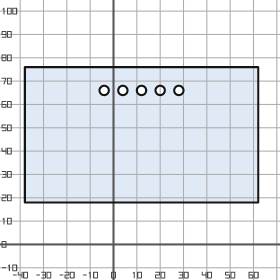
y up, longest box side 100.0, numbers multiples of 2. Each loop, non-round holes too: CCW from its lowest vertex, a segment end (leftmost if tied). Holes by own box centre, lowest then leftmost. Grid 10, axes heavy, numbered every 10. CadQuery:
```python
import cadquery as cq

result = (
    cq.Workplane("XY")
    .moveTo(-38.0, 18.0)
    .lineTo(62.0, 18.0)
    .lineTo(62.0, 76.0)
    .lineTo(-38.0, 76.0)
    .close()
    .moveTo(-4.0, 66.0)
    .circle(2.0)
    .moveTo(4.0, 66.0)
    .circle(2.0)
    .moveTo(12.0, 66.0)
    .circle(2.0)
    .moveTo(20.0, 66.0)
    .circle(2.0)
    .moveTo(28.0, 66.0)
    .circle(2.0)
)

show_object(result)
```